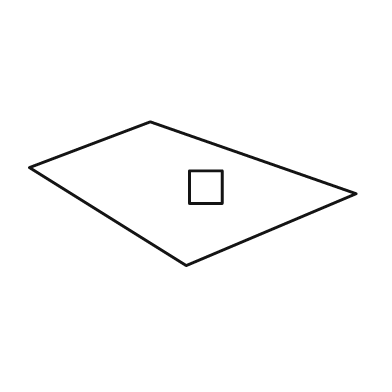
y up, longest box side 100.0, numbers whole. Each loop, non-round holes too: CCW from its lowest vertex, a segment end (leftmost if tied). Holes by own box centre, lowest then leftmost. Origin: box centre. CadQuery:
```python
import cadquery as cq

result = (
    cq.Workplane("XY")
    .moveTo(-2.0, -22.0)
    .lineTo(50.0, 0.0)
    .lineTo(-13.0, 22.0)
    .lineTo(-50.0, 8.0)
    .close()
    .moveTo(-1.0, -3.0)
    .lineTo(9.0, -3.0)
    .lineTo(9.0, 7.0)
    .lineTo(-1.0, 7.0)
    .close()
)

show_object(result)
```